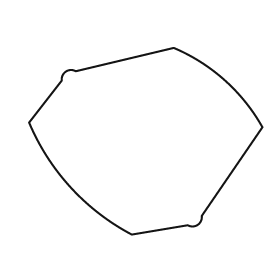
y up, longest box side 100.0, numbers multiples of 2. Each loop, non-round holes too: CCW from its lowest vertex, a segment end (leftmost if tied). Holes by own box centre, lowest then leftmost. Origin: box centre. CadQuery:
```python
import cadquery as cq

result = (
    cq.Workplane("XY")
    .moveTo(-6.0, -40.0)
    .lineTo(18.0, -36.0)
    .threePointArc((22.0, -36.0), (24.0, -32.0))
    .lineTo(50.0, 6.0)
    .threePointArc((34.0, 26.0), (12.0, 40.0))
    .lineTo(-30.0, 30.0)
    .threePointArc((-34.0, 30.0), (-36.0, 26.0))
    .lineTo(-50.0, 8.0)
    .threePointArc((-32.0, -20.0), (-6.0, -40.0))
    .close()
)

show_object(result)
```